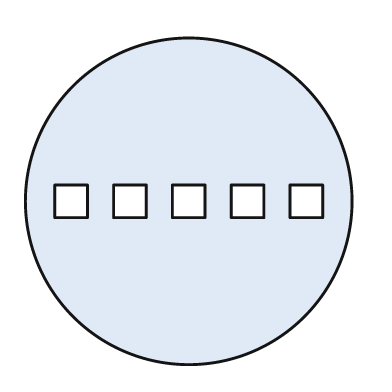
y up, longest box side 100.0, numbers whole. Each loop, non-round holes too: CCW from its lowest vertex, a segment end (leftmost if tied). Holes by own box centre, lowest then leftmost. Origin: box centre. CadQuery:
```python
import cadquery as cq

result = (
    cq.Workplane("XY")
    .moveTo(0.0, 0.0)
    .circle(50.0)
    .moveTo(-41.0, -5.0)
    .lineTo(-31.0, -5.0)
    .lineTo(-31.0, 5.0)
    .lineTo(-41.0, 5.0)
    .close()
    .moveTo(-23.0, -5.0)
    .lineTo(-13.0, -5.0)
    .lineTo(-13.0, 5.0)
    .lineTo(-23.0, 5.0)
    .close()
    .moveTo(-5.0, -5.0)
    .lineTo(5.0, -5.0)
    .lineTo(5.0, 5.0)
    .lineTo(-5.0, 5.0)
    .close()
    .moveTo(13.0, -5.0)
    .lineTo(23.0, -5.0)
    .lineTo(23.0, 5.0)
    .lineTo(13.0, 5.0)
    .close()
    .moveTo(31.0, -5.0)
    .lineTo(41.0, -5.0)
    .lineTo(41.0, 5.0)
    .lineTo(31.0, 5.0)
    .close()
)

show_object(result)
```